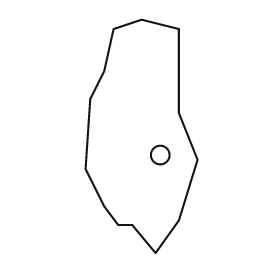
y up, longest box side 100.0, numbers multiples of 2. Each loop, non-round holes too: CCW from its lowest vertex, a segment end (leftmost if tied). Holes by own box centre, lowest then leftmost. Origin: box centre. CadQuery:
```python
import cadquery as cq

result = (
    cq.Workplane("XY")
    .moveTo(6.0, -50.0)
    .lineTo(16.0, -36.0)
    .lineTo(24.0, -10.0)
    .lineTo(16.0, 10.0)
    .lineTo(16.0, 46.0)
    .lineTo(0.0, 50.0)
    .lineTo(-12.0, 46.0)
    .lineTo(-16.0, 28.0)
    .lineTo(-22.0, 16.0)
    .lineTo(-24.0, -14.0)
    .lineTo(-16.0, -30.0)
    .lineTo(-10.0, -38.0)
    .lineTo(-4.0, -38.0)
    .close()
    .moveTo(8.0, -8.0)
    .circle(4.0)
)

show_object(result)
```